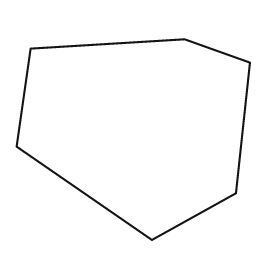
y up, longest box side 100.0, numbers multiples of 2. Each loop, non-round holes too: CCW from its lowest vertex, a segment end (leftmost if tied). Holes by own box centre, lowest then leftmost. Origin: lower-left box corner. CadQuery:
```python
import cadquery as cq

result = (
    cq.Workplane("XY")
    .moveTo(58.0, 0.0)
    .lineTo(94.0, 20.0)
    .lineTo(100.0, 76.0)
    .lineTo(72.0, 86.0)
    .lineTo(6.0, 82.0)
    .lineTo(0.0, 40.0)
    .close()
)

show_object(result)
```